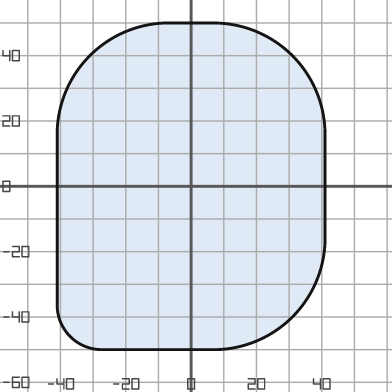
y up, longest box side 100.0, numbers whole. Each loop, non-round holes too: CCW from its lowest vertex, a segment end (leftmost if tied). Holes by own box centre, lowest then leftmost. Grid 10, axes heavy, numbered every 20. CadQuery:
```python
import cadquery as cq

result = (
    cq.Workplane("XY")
    .moveTo(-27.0, -50.0)
    .lineTo(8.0, -50.0)
    .threePointArc((31.0, -40.0), (41.0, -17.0))
    .lineTo(41.0, 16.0)
    .threePointArc((31.0, 40.0), (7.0, 50.0))
    .lineTo(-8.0, 50.0)
    .threePointArc((-31.0, 40.0), (-41.0, 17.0))
    .lineTo(-41.0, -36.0)
    .threePointArc((-37.0, -46.0), (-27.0, -50.0))
    .close()
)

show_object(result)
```